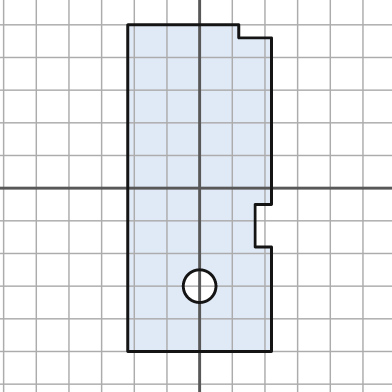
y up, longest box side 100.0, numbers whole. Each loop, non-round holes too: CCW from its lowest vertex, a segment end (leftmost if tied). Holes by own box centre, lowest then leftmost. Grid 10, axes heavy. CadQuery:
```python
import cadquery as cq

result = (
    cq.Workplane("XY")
    .moveTo(-22.0, -50.0)
    .lineTo(22.0, -50.0)
    .lineTo(22.0, -18.0)
    .lineTo(17.0, -18.0)
    .lineTo(17.0, -5.0)
    .lineTo(22.0, -5.0)
    .lineTo(22.0, 46.0)
    .lineTo(12.0, 46.0)
    .lineTo(12.0, 50.0)
    .lineTo(-22.0, 50.0)
    .close()
    .moveTo(0.0, -30.0)
    .circle(5.0)
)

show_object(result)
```